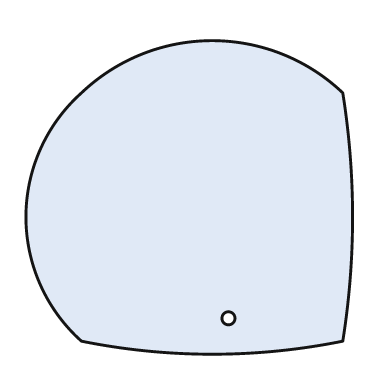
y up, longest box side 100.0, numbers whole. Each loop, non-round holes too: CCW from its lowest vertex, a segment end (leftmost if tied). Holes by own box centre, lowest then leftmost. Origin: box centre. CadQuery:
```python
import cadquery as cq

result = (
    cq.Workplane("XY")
    .moveTo(-33.0, -44.0)
    .threePointArc((7.0, -48.0), (47.0, -44.0))
    .threePointArc((50.0, -6.0), (47.0, 32.0))
    .threePointArc((7.0, 48.0), (-33.0, 32.0))
    .threePointArc((-50.0, -6.0), (-33.0, -44.0))
    .close()
    .moveTo(12.0, -37.0)
    .circle(2.0)
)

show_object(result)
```